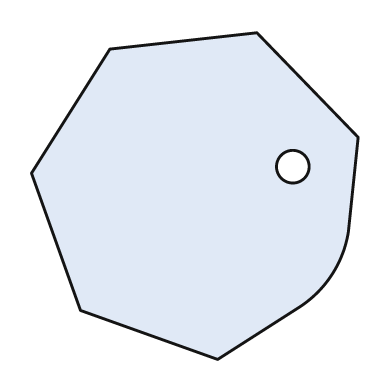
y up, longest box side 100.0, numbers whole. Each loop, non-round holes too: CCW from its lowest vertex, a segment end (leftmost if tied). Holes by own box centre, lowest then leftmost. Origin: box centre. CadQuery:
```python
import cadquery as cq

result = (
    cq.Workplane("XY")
    .moveTo(7.0, -50.0)
    .lineTo(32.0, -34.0)
    .threePointArc((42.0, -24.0), (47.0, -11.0))
    .lineTo(50.0, 18.0)
    .lineTo(19.0, 50.0)
    .lineTo(-26.0, 45.0)
    .lineTo(-50.0, 7.0)
    .lineTo(-35.0, -35.0)
    .close()
    .moveTo(30.0, 9.0)
    .circle(5.0)
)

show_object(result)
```